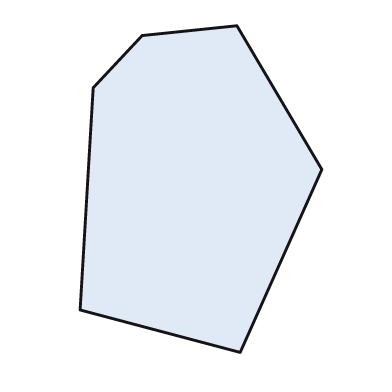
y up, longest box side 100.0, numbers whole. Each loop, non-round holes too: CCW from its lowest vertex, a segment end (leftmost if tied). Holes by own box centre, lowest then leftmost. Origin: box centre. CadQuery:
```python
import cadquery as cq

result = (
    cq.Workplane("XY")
    .moveTo(12.0, -50.0)
    .lineTo(37.0, 6.0)
    .lineTo(11.0, 50.0)
    .lineTo(-18.0, 47.0)
    .lineTo(-33.0, 31.0)
    .lineTo(-37.0, -37.0)
    .close()
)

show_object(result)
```